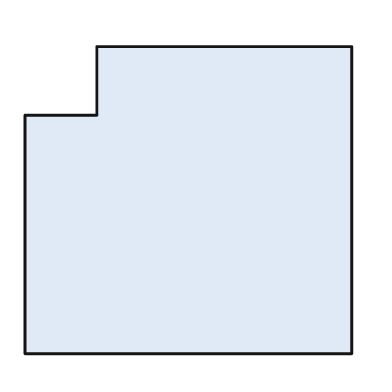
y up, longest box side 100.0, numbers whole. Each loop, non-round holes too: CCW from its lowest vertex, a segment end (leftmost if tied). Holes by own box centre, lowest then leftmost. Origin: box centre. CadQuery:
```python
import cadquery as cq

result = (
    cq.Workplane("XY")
    .moveTo(-50.0, -47.0)
    .lineTo(50.0, -47.0)
    .lineTo(50.0, 47.0)
    .lineTo(-28.0, 47.0)
    .lineTo(-28.0, 26.0)
    .lineTo(-50.0, 26.0)
    .close()
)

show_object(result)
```